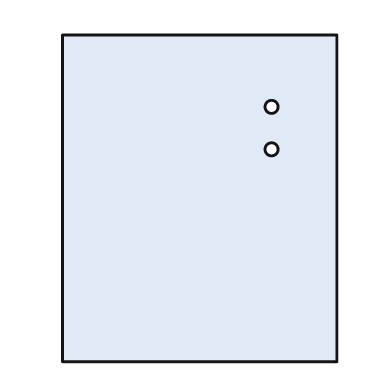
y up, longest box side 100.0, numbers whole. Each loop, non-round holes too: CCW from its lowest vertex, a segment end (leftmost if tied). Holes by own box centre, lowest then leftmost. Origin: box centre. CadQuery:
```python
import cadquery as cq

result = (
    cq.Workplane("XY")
    .moveTo(-42.0, -50.0)
    .lineTo(42.0, -50.0)
    .lineTo(42.0, 50.0)
    .lineTo(-42.0, 50.0)
    .close()
    .moveTo(22.0, 15.0)
    .circle(2.0)
    .moveTo(22.0, 28.0)
    .circle(2.0)
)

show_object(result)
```